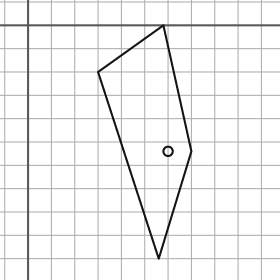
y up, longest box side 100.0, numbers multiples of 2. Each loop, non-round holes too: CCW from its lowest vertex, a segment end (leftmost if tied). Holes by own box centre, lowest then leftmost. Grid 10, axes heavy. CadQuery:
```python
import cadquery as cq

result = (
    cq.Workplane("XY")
    .moveTo(56.0, -100.0)
    .lineTo(70.0, -54.0)
    .lineTo(58.0, 0.0)
    .lineTo(30.0, -20.0)
    .close()
    .moveTo(60.0, -54.0)
    .circle(2.0)
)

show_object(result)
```